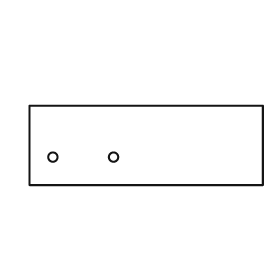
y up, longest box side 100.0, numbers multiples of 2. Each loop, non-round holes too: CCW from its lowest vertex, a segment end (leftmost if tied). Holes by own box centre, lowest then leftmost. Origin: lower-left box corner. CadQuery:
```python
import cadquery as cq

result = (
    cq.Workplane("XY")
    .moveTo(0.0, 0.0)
    .lineTo(100.0, 0.0)
    .lineTo(100.0, 34.0)
    .lineTo(0.0, 34.0)
    .close()
    .moveTo(10.0, 12.0)
    .circle(2.0)
    .moveTo(36.0, 12.0)
    .circle(2.0)
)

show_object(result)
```